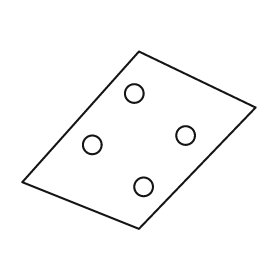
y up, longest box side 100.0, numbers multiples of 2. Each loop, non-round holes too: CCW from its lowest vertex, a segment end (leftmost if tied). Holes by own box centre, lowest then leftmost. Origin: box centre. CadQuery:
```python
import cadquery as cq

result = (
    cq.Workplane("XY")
    .moveTo(0.0, -38.0)
    .lineTo(50.0, 14.0)
    .lineTo(0.0, 38.0)
    .lineTo(-50.0, -18.0)
    .close()
    .moveTo(2.0, -20.0)
    .circle(4.0)
    .moveTo(-20.0, -2.0)
    .circle(4.0)
    .moveTo(20.0, 2.0)
    .circle(4.0)
    .moveTo(-2.0, 20.0)
    .circle(4.0)
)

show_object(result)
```